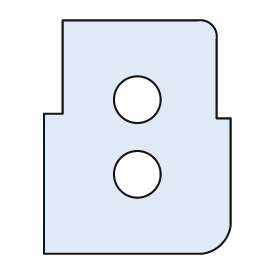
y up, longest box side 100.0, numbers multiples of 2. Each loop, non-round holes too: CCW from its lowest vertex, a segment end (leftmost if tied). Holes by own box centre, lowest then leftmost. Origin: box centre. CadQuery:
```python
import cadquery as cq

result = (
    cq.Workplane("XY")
    .moveTo(-40.0, -50.0)
    .lineTo(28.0, -50.0)
    .threePointArc((36.0, -46.0), (40.0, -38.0))
    .lineTo(40.0, 8.0)
    .lineTo(34.0, 8.0)
    .lineTo(34.0, 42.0)
    .threePointArc((32.0, 48.0), (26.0, 50.0))
    .lineTo(-32.0, 50.0)
    .lineTo(-32.0, 10.0)
    .lineTo(-40.0, 10.0)
    .close()
    .moveTo(0.0, -16.0)
    .circle(10.0)
    .moveTo(0.0, 16.0)
    .circle(10.0)
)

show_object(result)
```